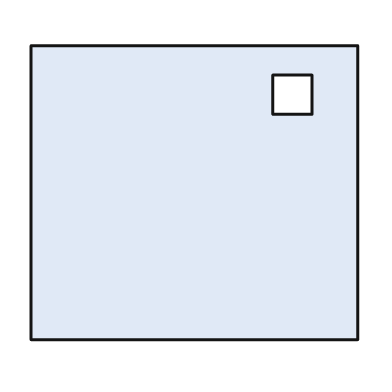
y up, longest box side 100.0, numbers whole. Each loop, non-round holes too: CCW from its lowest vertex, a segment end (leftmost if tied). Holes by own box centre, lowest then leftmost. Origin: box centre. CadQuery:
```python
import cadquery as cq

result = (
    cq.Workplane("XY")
    .moveTo(-50.0, -45.0)
    .lineTo(50.0, -45.0)
    .lineTo(50.0, 45.0)
    .lineTo(-50.0, 45.0)
    .close()
    .moveTo(24.0, 24.0)
    .lineTo(36.0, 24.0)
    .lineTo(36.0, 36.0)
    .lineTo(24.0, 36.0)
    .close()
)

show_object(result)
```